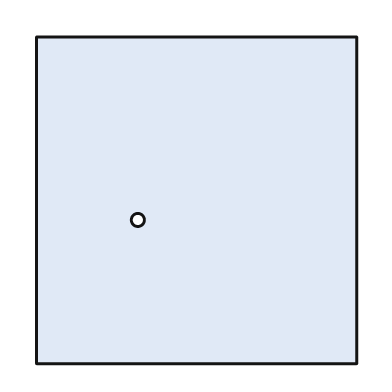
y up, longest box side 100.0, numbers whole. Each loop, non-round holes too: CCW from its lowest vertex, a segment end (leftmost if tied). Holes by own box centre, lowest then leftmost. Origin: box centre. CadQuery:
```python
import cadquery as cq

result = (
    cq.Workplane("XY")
    .moveTo(-49.0, -50.0)
    .lineTo(49.0, -50.0)
    .lineTo(49.0, 50.0)
    .lineTo(-49.0, 50.0)
    .close()
    .moveTo(-18.0, -6.0)
    .circle(2.0)
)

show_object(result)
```